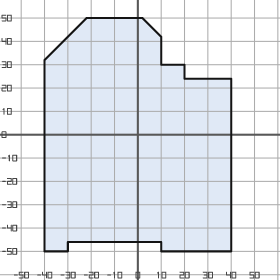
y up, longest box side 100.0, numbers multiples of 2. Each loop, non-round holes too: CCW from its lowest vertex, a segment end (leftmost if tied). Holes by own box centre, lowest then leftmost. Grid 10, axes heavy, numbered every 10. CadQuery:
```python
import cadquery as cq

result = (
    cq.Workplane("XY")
    .moveTo(-40.0, -50.0)
    .lineTo(-30.0, -50.0)
    .lineTo(-30.0, -46.0)
    .lineTo(10.0, -46.0)
    .lineTo(10.0, -50.0)
    .lineTo(40.0, -50.0)
    .lineTo(40.0, 24.0)
    .lineTo(20.0, 24.0)
    .lineTo(20.0, 30.0)
    .lineTo(10.0, 30.0)
    .lineTo(10.0, 42.0)
    .lineTo(2.0, 50.0)
    .lineTo(-22.0, 50.0)
    .lineTo(-40.0, 32.0)
    .close()
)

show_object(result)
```